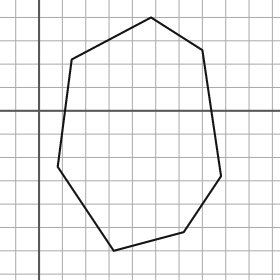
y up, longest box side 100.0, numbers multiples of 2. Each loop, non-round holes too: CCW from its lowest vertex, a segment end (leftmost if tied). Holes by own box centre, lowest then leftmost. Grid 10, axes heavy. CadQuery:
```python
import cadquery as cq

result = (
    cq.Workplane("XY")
    .moveTo(32.0, -60.0)
    .lineTo(62.0, -52.0)
    .lineTo(78.0, -28.0)
    .lineTo(70.0, 26.0)
    .lineTo(48.0, 40.0)
    .lineTo(14.0, 22.0)
    .lineTo(8.0, -24.0)
    .close()
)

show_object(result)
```